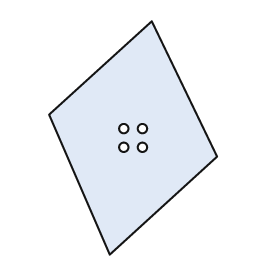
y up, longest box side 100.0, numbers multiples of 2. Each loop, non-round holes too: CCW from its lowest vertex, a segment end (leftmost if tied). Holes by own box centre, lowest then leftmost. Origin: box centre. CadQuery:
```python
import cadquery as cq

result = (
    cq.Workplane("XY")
    .moveTo(-10.0, -50.0)
    .lineTo(36.0, -8.0)
    .lineTo(8.0, 50.0)
    .lineTo(-36.0, 10.0)
    .close()
    .moveTo(-4.0, -4.0)
    .circle(2.0)
    .moveTo(4.0, -4.0)
    .circle(2.0)
    .moveTo(-4.0, 4.0)
    .circle(2.0)
    .moveTo(4.0, 4.0)
    .circle(2.0)
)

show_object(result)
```